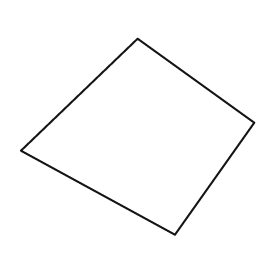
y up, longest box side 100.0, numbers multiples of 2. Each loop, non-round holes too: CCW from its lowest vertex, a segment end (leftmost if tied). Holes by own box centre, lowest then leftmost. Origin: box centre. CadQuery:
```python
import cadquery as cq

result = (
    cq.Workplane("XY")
    .moveTo(16.0, -42.0)
    .lineTo(50.0, 6.0)
    .lineTo(0.0, 42.0)
    .lineTo(-50.0, -6.0)
    .close()
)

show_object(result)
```